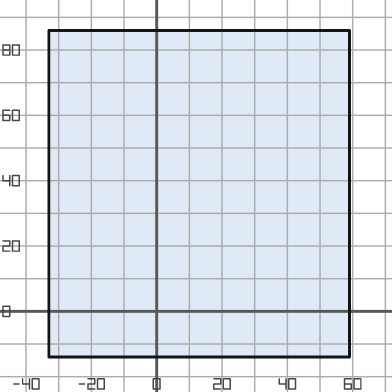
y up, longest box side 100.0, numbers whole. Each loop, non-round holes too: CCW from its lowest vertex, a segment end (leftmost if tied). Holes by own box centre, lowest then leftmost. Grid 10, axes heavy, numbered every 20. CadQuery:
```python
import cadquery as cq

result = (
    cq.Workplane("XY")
    .moveTo(-33.0, -14.0)
    .lineTo(59.0, -14.0)
    .lineTo(59.0, 86.0)
    .lineTo(-33.0, 86.0)
    .close()
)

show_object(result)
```